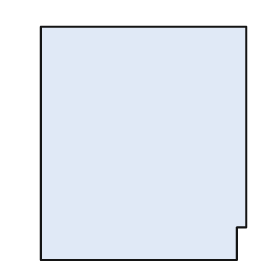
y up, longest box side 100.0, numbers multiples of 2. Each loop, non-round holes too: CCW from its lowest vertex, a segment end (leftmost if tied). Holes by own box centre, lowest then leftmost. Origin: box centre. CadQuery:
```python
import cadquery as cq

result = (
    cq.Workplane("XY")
    .moveTo(-44.0, -50.0)
    .lineTo(40.0, -50.0)
    .lineTo(40.0, -36.0)
    .lineTo(44.0, -36.0)
    .lineTo(44.0, 50.0)
    .lineTo(-44.0, 50.0)
    .close()
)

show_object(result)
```